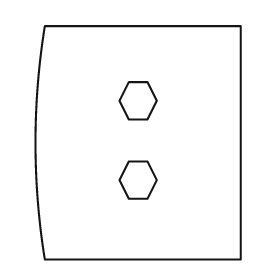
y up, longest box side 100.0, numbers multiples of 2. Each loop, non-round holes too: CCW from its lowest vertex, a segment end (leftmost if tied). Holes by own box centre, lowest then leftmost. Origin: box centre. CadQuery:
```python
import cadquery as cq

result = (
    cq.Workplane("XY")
    .moveTo(-40.0, -50.0)
    .lineTo(44.0, -50.0)
    .lineTo(44.0, 50.0)
    .lineTo(-40.0, 50.0)
    .threePointArc((-44.0, 0.0), (-40.0, -50.0))
    .close()
    .moveTo(-4.0, -24.0)
    .lineTo(4.0, -24.0)
    .lineTo(8.0, -16.0)
    .lineTo(4.0, -8.0)
    .lineTo(-4.0, -8.0)
    .lineTo(-8.0, -16.0)
    .close()
    .moveTo(-4.0, 10.0)
    .lineTo(4.0, 10.0)
    .lineTo(8.0, 18.0)
    .lineTo(4.0, 26.0)
    .lineTo(-4.0, 26.0)
    .lineTo(-8.0, 18.0)
    .close()
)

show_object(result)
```